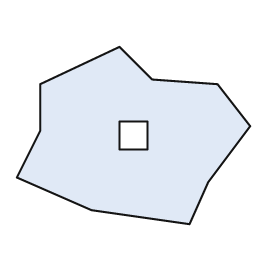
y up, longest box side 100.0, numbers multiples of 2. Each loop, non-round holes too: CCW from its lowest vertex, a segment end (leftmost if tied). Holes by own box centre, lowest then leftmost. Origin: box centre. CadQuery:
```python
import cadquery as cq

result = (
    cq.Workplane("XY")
    .moveTo(24.0, -38.0)
    .lineTo(32.0, -20.0)
    .lineTo(50.0, 4.0)
    .lineTo(36.0, 22.0)
    .lineTo(8.0, 24.0)
    .lineTo(-6.0, 38.0)
    .lineTo(-40.0, 22.0)
    .lineTo(-40.0, 2.0)
    .lineTo(-50.0, -18.0)
    .lineTo(-18.0, -32.0)
    .close()
    .moveTo(-6.0, -6.0)
    .lineTo(6.0, -6.0)
    .lineTo(6.0, 6.0)
    .lineTo(-6.0, 6.0)
    .close()
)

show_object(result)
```